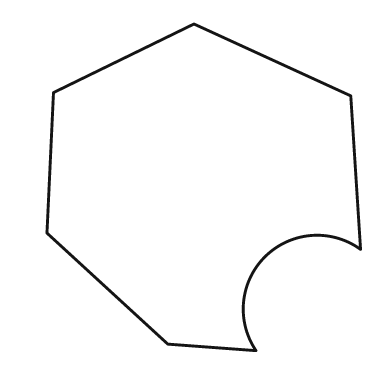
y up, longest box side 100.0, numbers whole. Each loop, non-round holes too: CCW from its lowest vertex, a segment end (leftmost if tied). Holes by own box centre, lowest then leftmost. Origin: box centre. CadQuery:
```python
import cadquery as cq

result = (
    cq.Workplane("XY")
    .moveTo(16.0, -50.0)
    .threePointArc((19.0, -21.0), (48.0, -19.0))
    .lineTo(45.0, 28.0)
    .lineTo(-3.0, 50.0)
    .lineTo(-46.0, 29.0)
    .lineTo(-48.0, -14.0)
    .lineTo(-11.0, -48.0)
    .close()
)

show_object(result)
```